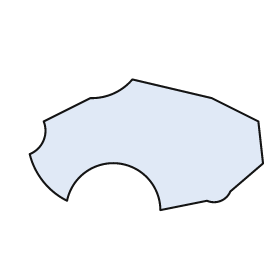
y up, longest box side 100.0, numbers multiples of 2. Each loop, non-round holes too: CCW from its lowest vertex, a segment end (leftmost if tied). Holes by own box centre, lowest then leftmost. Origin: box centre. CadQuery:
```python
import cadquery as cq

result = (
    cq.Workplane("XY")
    .moveTo(6.0, -28.0)
    .lineTo(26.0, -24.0)
    .threePointArc((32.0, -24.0), (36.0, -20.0))
    .lineTo(50.0, -8.0)
    .lineTo(48.0, 10.0)
    .lineTo(28.0, 20.0)
    .lineTo(-6.0, 28.0)
    .threePointArc((-14.0, 22.0), (-24.0, 20.0))
    .lineTo(-44.0, 10.0)
    .threePointArc((-44.0, 2.0), (-50.0, -4.0))
    .threePointArc((-44.0, -16.0), (-34.0, -24.0))
    .threePointArc((-12.0, -8.0), (6.0, -28.0))
    .close()
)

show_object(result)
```